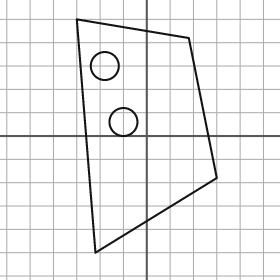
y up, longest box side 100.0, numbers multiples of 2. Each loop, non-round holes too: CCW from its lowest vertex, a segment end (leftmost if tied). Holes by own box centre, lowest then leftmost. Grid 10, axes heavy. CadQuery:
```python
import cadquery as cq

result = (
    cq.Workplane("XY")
    .moveTo(-22.0, -50.0)
    .lineTo(30.0, -18.0)
    .lineTo(18.0, 42.0)
    .lineTo(-30.0, 50.0)
    .close()
    .moveTo(-10.0, 6.0)
    .circle(6.0)
    .moveTo(-18.0, 30.0)
    .circle(6.0)
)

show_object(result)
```